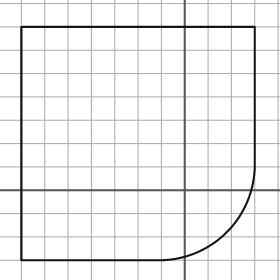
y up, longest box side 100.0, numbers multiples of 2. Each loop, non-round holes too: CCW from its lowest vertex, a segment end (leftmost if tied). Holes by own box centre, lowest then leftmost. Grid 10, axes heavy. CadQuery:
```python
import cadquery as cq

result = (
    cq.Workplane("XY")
    .moveTo(-70.0, -30.0)
    .lineTo(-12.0, -30.0)
    .threePointArc((18.0, -18.0), (30.0, 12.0))
    .lineTo(30.0, 70.0)
    .lineTo(-70.0, 70.0)
    .close()
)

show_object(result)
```